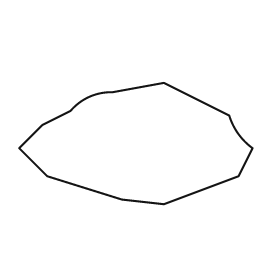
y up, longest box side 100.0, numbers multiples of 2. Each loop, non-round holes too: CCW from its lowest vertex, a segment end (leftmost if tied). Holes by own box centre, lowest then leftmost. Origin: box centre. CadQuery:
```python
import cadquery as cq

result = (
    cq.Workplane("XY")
    .moveTo(12.0, -26.0)
    .lineTo(44.0, -14.0)
    .lineTo(50.0, -2.0)
    .threePointArc((44.0, 4.0), (40.0, 12.0))
    .lineTo(12.0, 26.0)
    .lineTo(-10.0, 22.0)
    .threePointArc((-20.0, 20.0), (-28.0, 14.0))
    .lineTo(-40.0, 8.0)
    .lineTo(-50.0, -2.0)
    .lineTo(-38.0, -14.0)
    .lineTo(-6.0, -24.0)
    .close()
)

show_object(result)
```